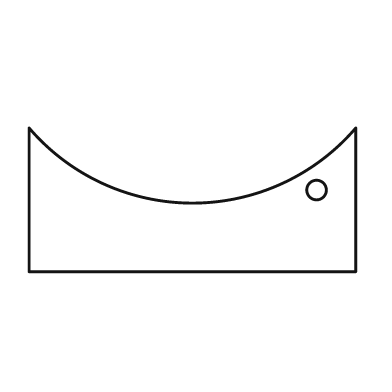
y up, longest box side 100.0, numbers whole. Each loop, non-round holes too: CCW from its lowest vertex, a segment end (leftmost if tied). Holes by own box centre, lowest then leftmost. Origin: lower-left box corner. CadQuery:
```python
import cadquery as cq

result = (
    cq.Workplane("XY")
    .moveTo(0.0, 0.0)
    .lineTo(100.0, 0.0)
    .lineTo(100.0, 44.0)
    .threePointArc((50.0, 21.0), (0.0, 44.0))
    .close()
    .moveTo(88.0, 25.0)
    .circle(3.0)
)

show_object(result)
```